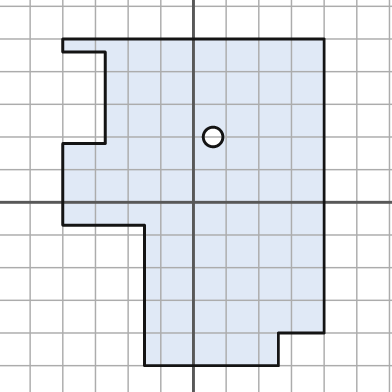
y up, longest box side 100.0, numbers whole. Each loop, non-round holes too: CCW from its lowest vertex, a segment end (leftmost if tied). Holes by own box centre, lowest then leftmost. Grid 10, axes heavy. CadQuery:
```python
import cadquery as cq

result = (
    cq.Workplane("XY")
    .moveTo(-15.0, -50.0)
    .lineTo(26.0, -50.0)
    .lineTo(26.0, -40.0)
    .lineTo(40.0, -40.0)
    .lineTo(40.0, 50.0)
    .lineTo(-40.0, 50.0)
    .lineTo(-40.0, 46.0)
    .lineTo(-27.0, 46.0)
    .lineTo(-27.0, 18.0)
    .lineTo(-40.0, 18.0)
    .lineTo(-40.0, -7.0)
    .lineTo(-15.0, -7.0)
    .close()
    .moveTo(6.0, 20.0)
    .circle(3.0)
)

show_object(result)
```